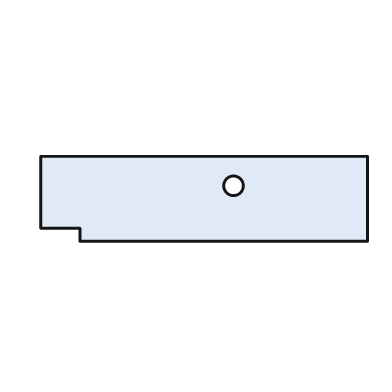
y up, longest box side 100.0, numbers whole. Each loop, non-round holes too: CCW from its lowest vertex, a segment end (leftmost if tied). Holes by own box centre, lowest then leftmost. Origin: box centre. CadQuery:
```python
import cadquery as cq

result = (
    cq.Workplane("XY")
    .moveTo(-38.0, -13.0)
    .lineTo(50.0, -13.0)
    .lineTo(50.0, 13.0)
    .lineTo(-50.0, 13.0)
    .lineTo(-50.0, -9.0)
    .lineTo(-38.0, -9.0)
    .close()
    .moveTo(9.0, 4.0)
    .circle(3.0)
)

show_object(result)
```